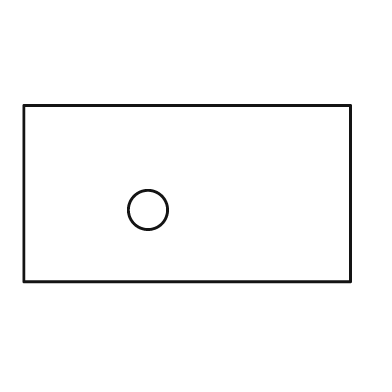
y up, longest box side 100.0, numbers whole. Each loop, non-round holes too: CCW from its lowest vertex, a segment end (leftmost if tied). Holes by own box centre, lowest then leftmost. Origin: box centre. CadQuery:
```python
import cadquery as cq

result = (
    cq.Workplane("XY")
    .moveTo(-50.0, -27.0)
    .lineTo(50.0, -27.0)
    .lineTo(50.0, 27.0)
    .lineTo(-50.0, 27.0)
    .close()
    .moveTo(-12.0, -5.0)
    .circle(6.0)
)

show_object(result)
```